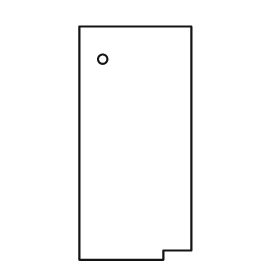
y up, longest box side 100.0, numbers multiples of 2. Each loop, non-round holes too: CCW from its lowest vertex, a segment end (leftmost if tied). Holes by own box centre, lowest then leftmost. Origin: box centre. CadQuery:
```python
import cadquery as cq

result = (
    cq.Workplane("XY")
    .moveTo(-24.0, -50.0)
    .lineTo(12.0, -50.0)
    .lineTo(12.0, -46.0)
    .lineTo(24.0, -46.0)
    .lineTo(24.0, 50.0)
    .lineTo(-24.0, 50.0)
    .close()
    .moveTo(-14.0, 36.0)
    .circle(2.0)
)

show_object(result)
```